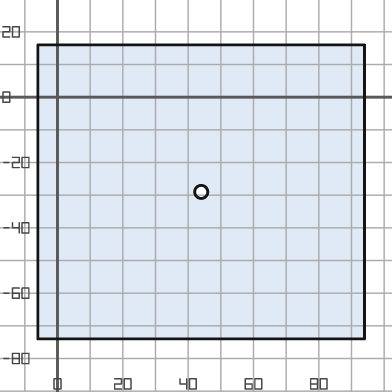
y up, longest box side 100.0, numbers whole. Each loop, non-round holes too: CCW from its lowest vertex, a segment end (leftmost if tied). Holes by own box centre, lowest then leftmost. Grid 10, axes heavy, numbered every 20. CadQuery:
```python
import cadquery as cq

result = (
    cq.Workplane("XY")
    .moveTo(-6.0, -74.0)
    .lineTo(94.0, -74.0)
    .lineTo(94.0, 16.0)
    .lineTo(-6.0, 16.0)
    .close()
    .moveTo(44.0, -29.0)
    .circle(2.0)
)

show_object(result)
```